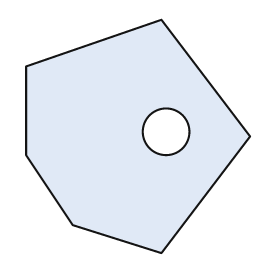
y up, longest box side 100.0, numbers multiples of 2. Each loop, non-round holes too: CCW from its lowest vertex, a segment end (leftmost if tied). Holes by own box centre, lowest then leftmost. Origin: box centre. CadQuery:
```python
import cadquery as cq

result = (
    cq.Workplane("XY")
    .moveTo(10.0, -50.0)
    .lineTo(48.0, 0.0)
    .lineTo(10.0, 50.0)
    .lineTo(-48.0, 30.0)
    .lineTo(-48.0, -8.0)
    .lineTo(-28.0, -38.0)
    .close()
    .moveTo(12.0, 2.0)
    .circle(10.0)
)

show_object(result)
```